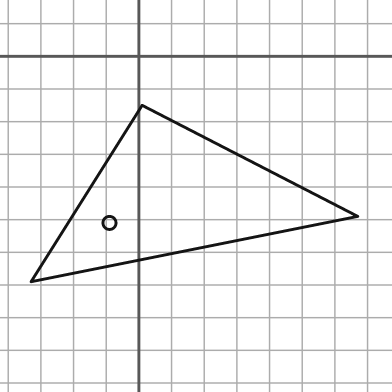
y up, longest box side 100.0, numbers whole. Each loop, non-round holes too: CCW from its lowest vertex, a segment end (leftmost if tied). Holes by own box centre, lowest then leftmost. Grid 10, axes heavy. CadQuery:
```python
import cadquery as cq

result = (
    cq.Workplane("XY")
    .moveTo(-33.0, -69.0)
    .lineTo(67.0, -49.0)
    .lineTo(1.0, -15.0)
    .close()
    .moveTo(-9.0, -51.0)
    .circle(2.0)
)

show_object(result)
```